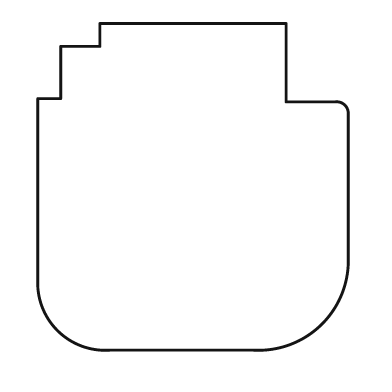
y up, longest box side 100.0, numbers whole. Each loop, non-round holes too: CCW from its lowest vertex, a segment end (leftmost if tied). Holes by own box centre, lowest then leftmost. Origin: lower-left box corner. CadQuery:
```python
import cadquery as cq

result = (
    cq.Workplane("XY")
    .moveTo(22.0, 0.0)
    .lineTo(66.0, 0.0)
    .threePointArc((87.0, 8.0), (95.0, 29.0))
    .lineTo(95.0, 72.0)
    .threePointArc((94.0, 75.0), (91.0, 76.0))
    .lineTo(76.0, 76.0)
    .lineTo(76.0, 100.0)
    .lineTo(19.0, 100.0)
    .lineTo(19.0, 93.0)
    .lineTo(7.0, 93.0)
    .lineTo(7.0, 77.0)
    .lineTo(0.0, 77.0)
    .lineTo(0.0, 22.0)
    .threePointArc((6.0, 6.0), (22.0, 0.0))
    .close()
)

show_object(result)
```